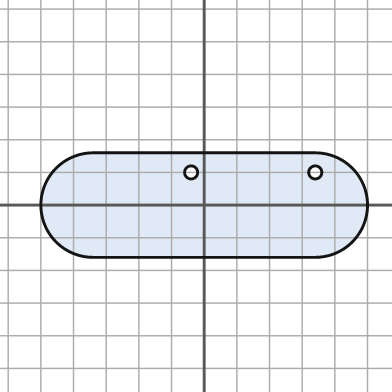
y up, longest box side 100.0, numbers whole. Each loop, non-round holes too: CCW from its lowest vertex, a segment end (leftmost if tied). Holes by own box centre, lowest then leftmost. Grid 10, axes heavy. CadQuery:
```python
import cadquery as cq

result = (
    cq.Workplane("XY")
    .moveTo(-34.0, -16.0)
    .lineTo(34.0, -16.0)
    .threePointArc((50.0, 0.0), (34.0, 16.0))
    .lineTo(-34.0, 16.0)
    .threePointArc((-50.0, 0.0), (-34.0, -16.0))
    .close()
    .moveTo(-4.0, 10.0)
    .circle(2.0)
    .moveTo(34.0, 10.0)
    .circle(2.0)
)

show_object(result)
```